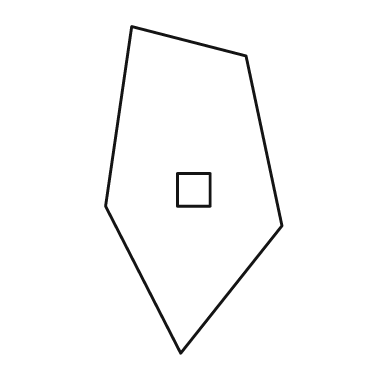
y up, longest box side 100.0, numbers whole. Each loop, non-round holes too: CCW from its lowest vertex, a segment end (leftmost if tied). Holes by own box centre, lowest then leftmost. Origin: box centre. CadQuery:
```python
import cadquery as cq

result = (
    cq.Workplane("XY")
    .moveTo(-4.0, -50.0)
    .lineTo(27.0, -11.0)
    .lineTo(16.0, 41.0)
    .lineTo(-19.0, 50.0)
    .lineTo(-27.0, -5.0)
    .close()
    .moveTo(-5.0, -5.0)
    .lineTo(5.0, -5.0)
    .lineTo(5.0, 5.0)
    .lineTo(-5.0, 5.0)
    .close()
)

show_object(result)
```